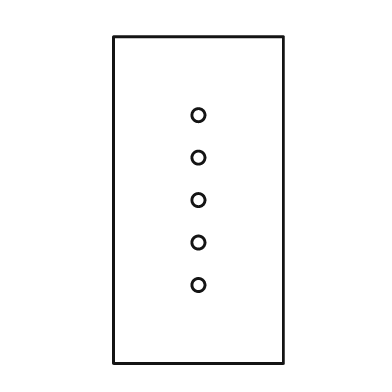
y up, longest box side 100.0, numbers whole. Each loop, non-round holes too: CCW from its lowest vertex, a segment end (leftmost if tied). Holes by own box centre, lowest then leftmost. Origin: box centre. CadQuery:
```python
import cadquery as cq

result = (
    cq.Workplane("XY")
    .moveTo(-26.0, -50.0)
    .lineTo(26.0, -50.0)
    .lineTo(26.0, 50.0)
    .lineTo(-26.0, 50.0)
    .close()
    .moveTo(0.0, -26.0)
    .circle(2.0)
    .moveTo(0.0, -13.0)
    .circle(2.0)
    .moveTo(0.0, 0.0)
    .circle(2.0)
    .moveTo(0.0, 13.0)
    .circle(2.0)
    .moveTo(0.0, 26.0)
    .circle(2.0)
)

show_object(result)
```